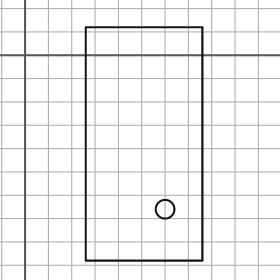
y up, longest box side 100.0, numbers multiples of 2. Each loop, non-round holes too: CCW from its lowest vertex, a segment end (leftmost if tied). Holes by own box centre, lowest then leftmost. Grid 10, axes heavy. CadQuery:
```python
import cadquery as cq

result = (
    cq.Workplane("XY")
    .moveTo(26.0, -88.0)
    .lineTo(76.0, -88.0)
    .lineTo(76.0, 12.0)
    .lineTo(26.0, 12.0)
    .close()
    .moveTo(60.0, -66.0)
    .circle(4.0)
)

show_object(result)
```